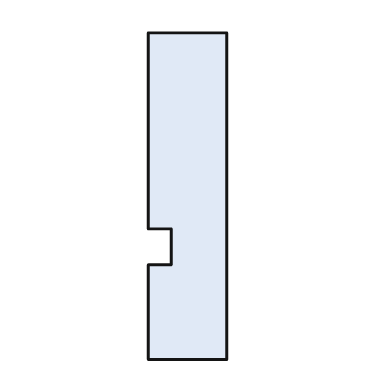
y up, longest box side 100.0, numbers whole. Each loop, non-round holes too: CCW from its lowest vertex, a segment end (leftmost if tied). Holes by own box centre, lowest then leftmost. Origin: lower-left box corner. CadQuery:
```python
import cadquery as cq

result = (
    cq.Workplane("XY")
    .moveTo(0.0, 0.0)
    .lineTo(24.0, 0.0)
    .lineTo(24.0, 100.0)
    .lineTo(0.0, 100.0)
    .lineTo(0.0, 40.0)
    .lineTo(7.0, 40.0)
    .lineTo(7.0, 29.0)
    .lineTo(0.0, 29.0)
    .close()
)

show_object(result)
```